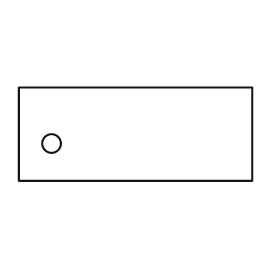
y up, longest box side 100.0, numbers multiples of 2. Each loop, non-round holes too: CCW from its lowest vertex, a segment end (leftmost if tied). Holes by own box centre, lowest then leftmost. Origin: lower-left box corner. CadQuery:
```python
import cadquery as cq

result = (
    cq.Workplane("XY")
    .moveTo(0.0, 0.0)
    .lineTo(100.0, 0.0)
    .lineTo(100.0, 40.0)
    .lineTo(0.0, 40.0)
    .close()
    .moveTo(14.0, 16.0)
    .circle(4.0)
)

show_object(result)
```